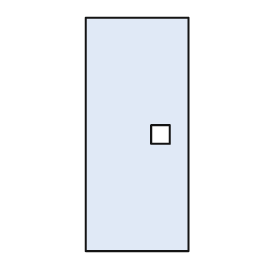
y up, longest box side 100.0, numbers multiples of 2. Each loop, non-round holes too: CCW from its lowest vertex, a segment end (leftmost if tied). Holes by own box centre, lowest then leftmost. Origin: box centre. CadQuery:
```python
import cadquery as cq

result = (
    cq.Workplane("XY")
    .moveTo(-22.0, -50.0)
    .lineTo(22.0, -50.0)
    .lineTo(22.0, 50.0)
    .lineTo(-22.0, 50.0)
    .close()
    .moveTo(6.0, -4.0)
    .lineTo(14.0, -4.0)
    .lineTo(14.0, 4.0)
    .lineTo(6.0, 4.0)
    .close()
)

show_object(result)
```